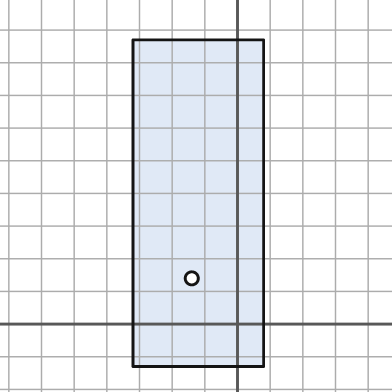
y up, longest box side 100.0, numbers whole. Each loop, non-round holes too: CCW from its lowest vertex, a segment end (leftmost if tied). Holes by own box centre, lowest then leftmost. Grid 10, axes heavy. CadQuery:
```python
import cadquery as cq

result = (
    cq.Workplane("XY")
    .moveTo(-32.0, -13.0)
    .lineTo(8.0, -13.0)
    .lineTo(8.0, 87.0)
    .lineTo(-32.0, 87.0)
    .close()
    .moveTo(-14.0, 14.0)
    .circle(2.0)
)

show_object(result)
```